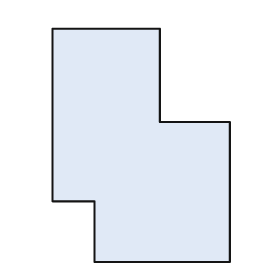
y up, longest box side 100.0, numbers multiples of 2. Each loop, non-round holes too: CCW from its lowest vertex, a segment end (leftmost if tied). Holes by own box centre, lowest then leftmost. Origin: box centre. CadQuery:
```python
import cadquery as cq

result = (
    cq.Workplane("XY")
    .moveTo(-20.0, -50.0)
    .lineTo(38.0, -50.0)
    .lineTo(38.0, 10.0)
    .lineTo(8.0, 10.0)
    .lineTo(8.0, 50.0)
    .lineTo(-38.0, 50.0)
    .lineTo(-38.0, -24.0)
    .lineTo(-20.0, -24.0)
    .close()
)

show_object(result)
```